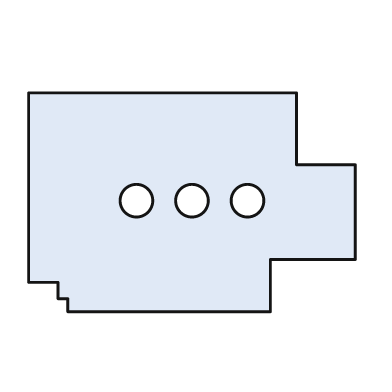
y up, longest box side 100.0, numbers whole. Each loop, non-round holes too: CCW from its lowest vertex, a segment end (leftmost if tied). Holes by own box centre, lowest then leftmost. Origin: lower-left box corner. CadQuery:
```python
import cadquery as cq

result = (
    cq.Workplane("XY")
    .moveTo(12.0, 0.0)
    .lineTo(74.0, 0.0)
    .lineTo(74.0, 16.0)
    .lineTo(100.0, 16.0)
    .lineTo(100.0, 45.0)
    .lineTo(82.0, 45.0)
    .lineTo(82.0, 67.0)
    .lineTo(0.0, 67.0)
    .lineTo(0.0, 9.0)
    .lineTo(9.0, 9.0)
    .lineTo(9.0, 4.0)
    .lineTo(12.0, 4.0)
    .close()
    .moveTo(33.0, 34.0)
    .circle(5.0)
    .moveTo(50.0, 34.0)
    .circle(5.0)
    .moveTo(67.0, 34.0)
    .circle(5.0)
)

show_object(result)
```